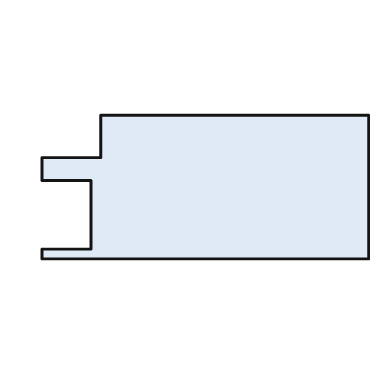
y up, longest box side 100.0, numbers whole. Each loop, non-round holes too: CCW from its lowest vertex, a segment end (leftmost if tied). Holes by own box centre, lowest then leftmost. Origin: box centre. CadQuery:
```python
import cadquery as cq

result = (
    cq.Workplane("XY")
    .moveTo(-50.0, -22.0)
    .lineTo(50.0, -22.0)
    .lineTo(50.0, 22.0)
    .lineTo(-32.0, 22.0)
    .lineTo(-32.0, 9.0)
    .lineTo(-50.0, 9.0)
    .lineTo(-50.0, 2.0)
    .lineTo(-35.0, 2.0)
    .lineTo(-35.0, -19.0)
    .lineTo(-50.0, -19.0)
    .close()
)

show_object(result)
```